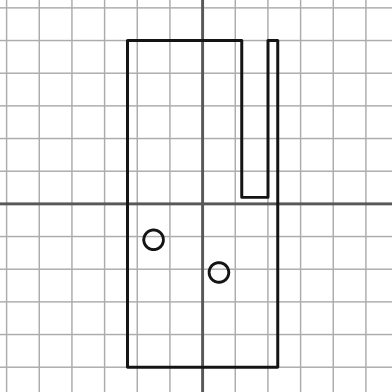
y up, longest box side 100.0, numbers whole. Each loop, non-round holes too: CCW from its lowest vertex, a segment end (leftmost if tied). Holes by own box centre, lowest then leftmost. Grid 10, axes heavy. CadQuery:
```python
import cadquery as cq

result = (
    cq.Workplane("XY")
    .moveTo(-23.0, -50.0)
    .lineTo(23.0, -50.0)
    .lineTo(23.0, 50.0)
    .lineTo(20.0, 50.0)
    .lineTo(20.0, 2.0)
    .lineTo(12.0, 2.0)
    .lineTo(12.0, 50.0)
    .lineTo(-23.0, 50.0)
    .close()
    .moveTo(5.0, -21.0)
    .circle(3.0)
    .moveTo(-15.0, -11.0)
    .circle(3.0)
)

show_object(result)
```